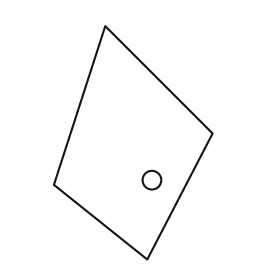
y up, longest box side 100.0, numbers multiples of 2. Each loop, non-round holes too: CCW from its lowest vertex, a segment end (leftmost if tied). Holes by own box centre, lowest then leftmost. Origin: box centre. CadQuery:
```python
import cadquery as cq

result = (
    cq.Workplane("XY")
    .moveTo(6.0, -50.0)
    .lineTo(34.0, 4.0)
    .lineTo(-12.0, 50.0)
    .lineTo(-34.0, -18.0)
    .close()
    .moveTo(8.0, -16.0)
    .circle(4.0)
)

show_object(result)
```